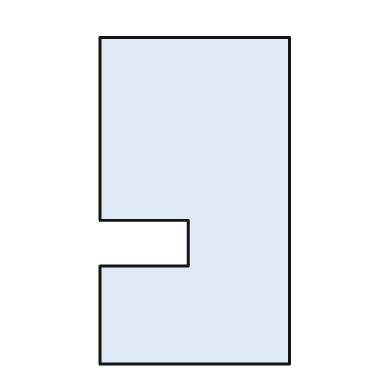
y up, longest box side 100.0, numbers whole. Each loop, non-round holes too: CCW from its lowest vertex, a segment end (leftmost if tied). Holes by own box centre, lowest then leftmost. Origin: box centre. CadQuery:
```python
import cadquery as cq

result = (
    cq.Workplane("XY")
    .moveTo(-29.0, -50.0)
    .lineTo(29.0, -50.0)
    .lineTo(29.0, 50.0)
    .lineTo(-29.0, 50.0)
    .lineTo(-29.0, -6.0)
    .lineTo(-2.0, -6.0)
    .lineTo(-2.0, -20.0)
    .lineTo(-29.0, -20.0)
    .close()
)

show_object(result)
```